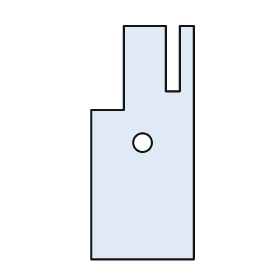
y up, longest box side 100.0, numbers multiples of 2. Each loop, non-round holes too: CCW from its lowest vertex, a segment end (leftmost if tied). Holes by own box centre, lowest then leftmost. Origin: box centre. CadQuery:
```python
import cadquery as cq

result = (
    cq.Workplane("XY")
    .moveTo(-22.0, -50.0)
    .lineTo(22.0, -50.0)
    .lineTo(22.0, 50.0)
    .lineTo(16.0, 50.0)
    .lineTo(16.0, 22.0)
    .lineTo(10.0, 22.0)
    .lineTo(10.0, 50.0)
    .lineTo(-8.0, 50.0)
    .lineTo(-8.0, 14.0)
    .lineTo(-22.0, 14.0)
    .close()
    .moveTo(0.0, 0.0)
    .circle(4.0)
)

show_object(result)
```